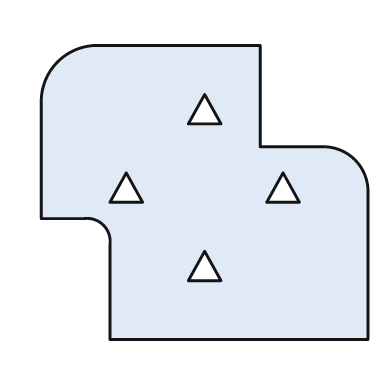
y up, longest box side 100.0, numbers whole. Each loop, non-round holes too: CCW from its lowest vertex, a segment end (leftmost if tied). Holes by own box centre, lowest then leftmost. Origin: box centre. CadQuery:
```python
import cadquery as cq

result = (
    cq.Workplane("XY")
    .moveTo(-29.0, -45.0)
    .lineTo(50.0, -45.0)
    .lineTo(50.0, 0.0)
    .threePointArc((46.0, 10.0), (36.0, 14.0))
    .lineTo(17.0, 14.0)
    .lineTo(17.0, 45.0)
    .lineTo(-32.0, 45.0)
    .threePointArc((-45.0, 40.0), (-50.0, 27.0))
    .lineTo(-50.0, -8.0)
    .lineTo(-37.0, -8.0)
    .threePointArc((-31.0, -10.0), (-29.0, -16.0))
    .close()
    .moveTo(-5.0, -27.0)
    .lineTo(5.0, -27.0)
    .lineTo(0.0, -18.0)
    .close()
    .moveTo(-29.0, -3.0)
    .lineTo(-19.0, -3.0)
    .lineTo(-24.0, 6.0)
    .close()
    .moveTo(19.0, -3.0)
    .lineTo(29.0, -3.0)
    .lineTo(24.0, 6.0)
    .close()
    .moveTo(-5.0, 21.0)
    .lineTo(5.0, 21.0)
    .lineTo(0.0, 30.0)
    .close()
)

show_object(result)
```